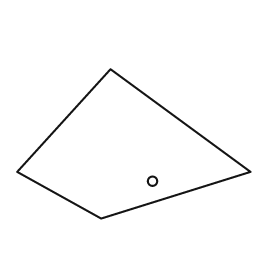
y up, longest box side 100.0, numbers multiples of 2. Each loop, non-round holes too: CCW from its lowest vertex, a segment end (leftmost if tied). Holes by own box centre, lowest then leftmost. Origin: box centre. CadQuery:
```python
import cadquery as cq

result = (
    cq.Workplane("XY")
    .moveTo(-14.0, -32.0)
    .lineTo(50.0, -12.0)
    .lineTo(-10.0, 32.0)
    .lineTo(-50.0, -12.0)
    .close()
    .moveTo(8.0, -16.0)
    .circle(2.0)
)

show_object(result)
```